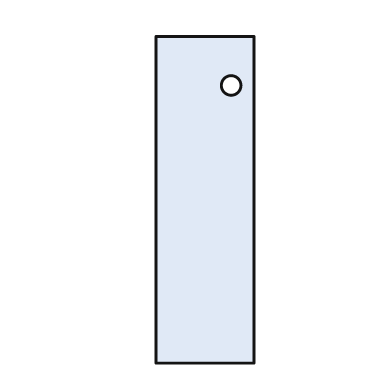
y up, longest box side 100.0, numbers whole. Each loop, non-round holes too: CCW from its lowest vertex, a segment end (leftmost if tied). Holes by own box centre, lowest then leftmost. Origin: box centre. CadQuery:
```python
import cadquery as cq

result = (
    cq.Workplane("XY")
    .moveTo(-15.0, -50.0)
    .lineTo(15.0, -50.0)
    .lineTo(15.0, 50.0)
    .lineTo(-15.0, 50.0)
    .close()
    .moveTo(8.0, 35.0)
    .circle(3.0)
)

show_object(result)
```